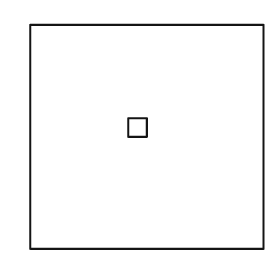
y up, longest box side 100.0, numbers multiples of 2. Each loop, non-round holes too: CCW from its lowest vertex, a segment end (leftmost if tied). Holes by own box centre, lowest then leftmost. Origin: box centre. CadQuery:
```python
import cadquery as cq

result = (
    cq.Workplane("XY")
    .moveTo(-50.0, -48.0)
    .lineTo(50.0, -48.0)
    .lineTo(50.0, 48.0)
    .lineTo(-50.0, 48.0)
    .close()
    .moveTo(-8.0, 0.0)
    .lineTo(0.0, 0.0)
    .lineTo(0.0, 8.0)
    .lineTo(-8.0, 8.0)
    .close()
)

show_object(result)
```